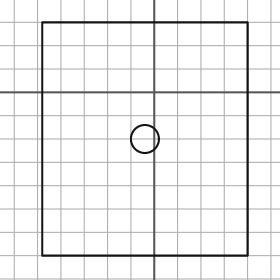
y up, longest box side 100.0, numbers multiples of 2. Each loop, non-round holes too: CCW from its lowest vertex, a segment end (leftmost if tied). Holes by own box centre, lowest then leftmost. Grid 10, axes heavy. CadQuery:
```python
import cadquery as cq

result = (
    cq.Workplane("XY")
    .moveTo(-48.0, -70.0)
    .lineTo(40.0, -70.0)
    .lineTo(40.0, 30.0)
    .lineTo(-48.0, 30.0)
    .close()
    .moveTo(-4.0, -20.0)
    .circle(6.0)
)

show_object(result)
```